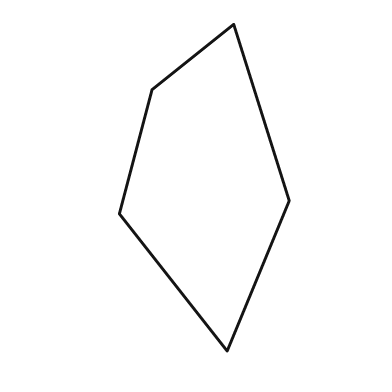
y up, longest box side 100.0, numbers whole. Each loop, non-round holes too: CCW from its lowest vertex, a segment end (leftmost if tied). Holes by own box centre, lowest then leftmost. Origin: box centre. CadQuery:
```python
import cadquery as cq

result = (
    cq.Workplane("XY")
    .moveTo(7.0, -50.0)
    .lineTo(26.0, -4.0)
    .lineTo(9.0, 50.0)
    .lineTo(-16.0, 30.0)
    .lineTo(-26.0, -8.0)
    .close()
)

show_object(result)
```